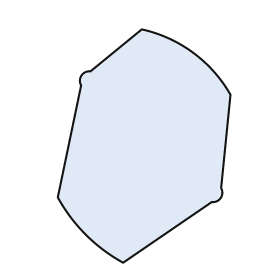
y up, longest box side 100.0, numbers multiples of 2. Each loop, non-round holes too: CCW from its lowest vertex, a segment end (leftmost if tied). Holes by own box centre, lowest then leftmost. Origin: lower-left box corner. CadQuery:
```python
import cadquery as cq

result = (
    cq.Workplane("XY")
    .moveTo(28.0, 0.0)
    .lineTo(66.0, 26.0)
    .threePointArc((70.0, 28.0), (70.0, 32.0))
    .lineTo(74.0, 72.0)
    .threePointArc((58.0, 90.0), (36.0, 100.0))
    .lineTo(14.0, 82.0)
    .threePointArc((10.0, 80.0), (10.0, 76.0))
    .lineTo(0.0, 28.0)
    .threePointArc((12.0, 12.0), (28.0, 0.0))
    .close()
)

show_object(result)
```